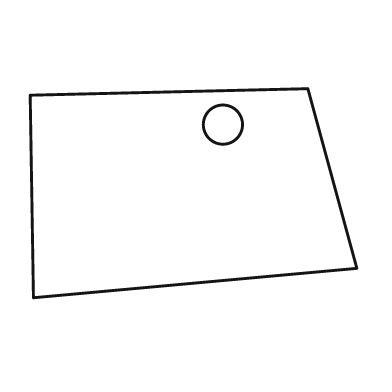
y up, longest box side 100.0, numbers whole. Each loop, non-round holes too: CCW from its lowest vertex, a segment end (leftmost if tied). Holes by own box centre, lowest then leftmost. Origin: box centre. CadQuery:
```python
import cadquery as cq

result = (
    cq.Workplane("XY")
    .moveTo(-49.0, -32.0)
    .lineTo(50.0, -23.0)
    .lineTo(35.0, 32.0)
    .lineTo(-50.0, 30.0)
    .close()
    .moveTo(9.0, 21.0)
    .circle(6.0)
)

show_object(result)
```